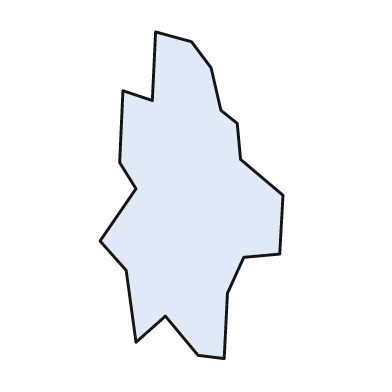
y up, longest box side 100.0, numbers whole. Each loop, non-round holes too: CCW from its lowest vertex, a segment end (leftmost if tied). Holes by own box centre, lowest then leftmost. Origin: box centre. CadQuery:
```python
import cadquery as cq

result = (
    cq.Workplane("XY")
    .moveTo(10.0, -50.0)
    .lineTo(11.0, -30.0)
    .lineTo(16.0, -19.0)
    .lineTo(27.0, -18.0)
    .lineTo(28.0, 0.0)
    .lineTo(15.0, 11.0)
    .lineTo(14.0, 22.0)
    .lineTo(9.0, 26.0)
    .lineTo(6.0, 39.0)
    .lineTo(0.0, 47.0)
    .lineTo(-11.0, 50.0)
    .lineTo(-12.0, 29.0)
    .lineTo(-21.0, 32.0)
    .lineTo(-22.0, 10.0)
    .lineTo(-17.0, 2.0)
    .lineTo(-28.0, -14.0)
    .lineTo(-20.0, -23.0)
    .lineTo(-17.0, -45.0)
    .lineTo(-8.0, -37.0)
    .lineTo(2.0, -49.0)
    .close()
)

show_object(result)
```